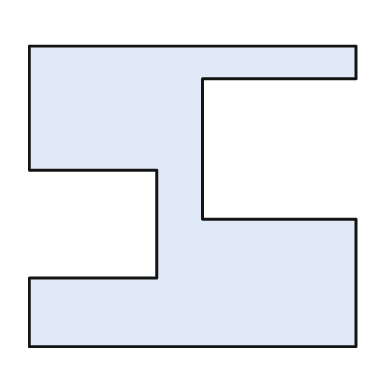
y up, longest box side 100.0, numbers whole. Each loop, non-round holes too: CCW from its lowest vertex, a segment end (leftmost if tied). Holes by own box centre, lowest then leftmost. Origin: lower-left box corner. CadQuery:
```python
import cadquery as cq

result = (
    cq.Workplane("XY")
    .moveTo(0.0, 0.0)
    .lineTo(100.0, 0.0)
    .lineTo(100.0, 39.0)
    .lineTo(53.0, 39.0)
    .lineTo(53.0, 82.0)
    .lineTo(100.0, 82.0)
    .lineTo(100.0, 92.0)
    .lineTo(0.0, 92.0)
    .lineTo(0.0, 54.0)
    .lineTo(39.0, 54.0)
    .lineTo(39.0, 21.0)
    .lineTo(0.0, 21.0)
    .close()
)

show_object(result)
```